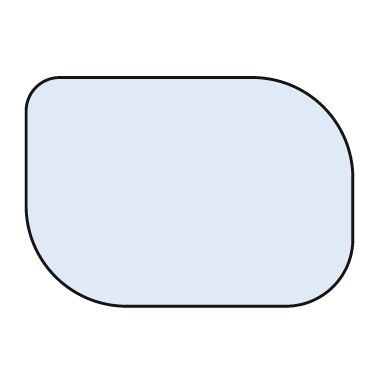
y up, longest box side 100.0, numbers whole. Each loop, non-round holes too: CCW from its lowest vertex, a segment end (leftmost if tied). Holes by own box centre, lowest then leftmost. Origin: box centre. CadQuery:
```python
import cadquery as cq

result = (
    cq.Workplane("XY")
    .moveTo(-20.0, -35.0)
    .lineTo(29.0, -35.0)
    .threePointArc((44.0, -29.0), (50.0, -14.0))
    .lineTo(50.0, 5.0)
    .threePointArc((41.0, 26.0), (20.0, 35.0))
    .lineTo(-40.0, 35.0)
    .threePointArc((-47.0, 32.0), (-50.0, 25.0))
    .lineTo(-50.0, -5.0)
    .threePointArc((-41.0, -26.0), (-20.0, -35.0))
    .close()
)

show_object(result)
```